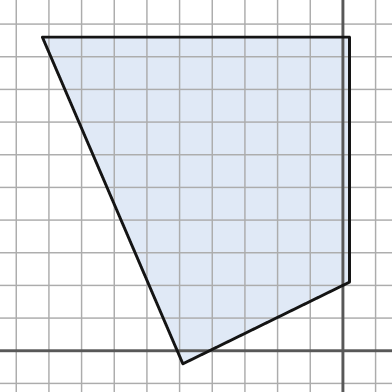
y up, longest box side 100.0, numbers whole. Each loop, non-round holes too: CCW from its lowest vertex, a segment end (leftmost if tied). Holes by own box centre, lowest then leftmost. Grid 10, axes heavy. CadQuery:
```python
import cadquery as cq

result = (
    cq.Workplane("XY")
    .moveTo(-49.0, -4.0)
    .lineTo(2.0, 21.0)
    .lineTo(2.0, 96.0)
    .lineTo(-92.0, 96.0)
    .close()
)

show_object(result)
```